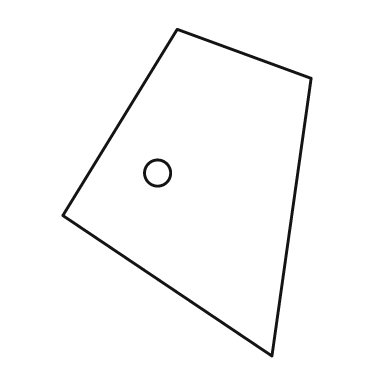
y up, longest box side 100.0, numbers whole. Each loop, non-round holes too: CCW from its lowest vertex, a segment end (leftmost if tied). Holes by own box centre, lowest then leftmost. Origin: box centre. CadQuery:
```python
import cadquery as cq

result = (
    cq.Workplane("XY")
    .moveTo(26.0, -50.0)
    .lineTo(38.0, 35.0)
    .lineTo(-3.0, 50.0)
    .lineTo(-38.0, -7.0)
    .close()
    .moveTo(-9.0, 6.0)
    .circle(4.0)
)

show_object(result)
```